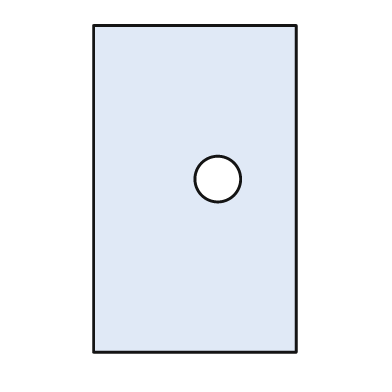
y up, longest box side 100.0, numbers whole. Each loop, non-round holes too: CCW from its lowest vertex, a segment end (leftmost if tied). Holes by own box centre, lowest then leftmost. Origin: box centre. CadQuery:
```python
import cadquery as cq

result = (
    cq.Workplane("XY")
    .moveTo(-31.0, -50.0)
    .lineTo(31.0, -50.0)
    .lineTo(31.0, 50.0)
    .lineTo(-31.0, 50.0)
    .close()
    .moveTo(7.0, 3.0)
    .circle(7.0)
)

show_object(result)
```